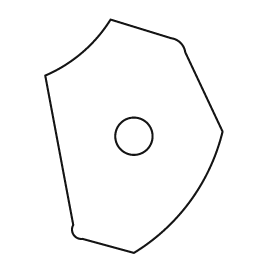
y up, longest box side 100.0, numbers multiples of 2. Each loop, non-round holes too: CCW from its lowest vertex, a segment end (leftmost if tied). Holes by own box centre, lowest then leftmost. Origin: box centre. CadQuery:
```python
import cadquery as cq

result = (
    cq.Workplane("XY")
    .moveTo(0.0, -50.0)
    .threePointArc((24.0, -28.0), (38.0, 2.0))
    .lineTo(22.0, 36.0)
    .threePointArc((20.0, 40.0), (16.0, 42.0))
    .lineTo(-10.0, 50.0)
    .threePointArc((-22.0, 36.0), (-38.0, 26.0))
    .lineTo(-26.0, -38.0)
    .threePointArc((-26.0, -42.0), (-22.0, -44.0))
    .close()
    .moveTo(0.0, 0.0)
    .circle(8.0)
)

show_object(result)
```